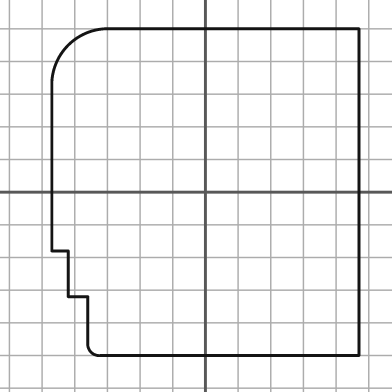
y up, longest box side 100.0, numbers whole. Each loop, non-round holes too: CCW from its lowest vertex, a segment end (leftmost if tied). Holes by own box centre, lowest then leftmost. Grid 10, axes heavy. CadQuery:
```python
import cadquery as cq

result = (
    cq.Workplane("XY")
    .moveTo(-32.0, -50.0)
    .lineTo(47.0, -50.0)
    .lineTo(47.0, 50.0)
    .lineTo(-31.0, 50.0)
    .threePointArc((-42.0, 45.0), (-47.0, 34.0))
    .lineTo(-47.0, -18.0)
    .lineTo(-42.0, -18.0)
    .lineTo(-42.0, -32.0)
    .lineTo(-36.0, -32.0)
    .lineTo(-36.0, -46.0)
    .threePointArc((-35.0, -49.0), (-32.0, -50.0))
    .close()
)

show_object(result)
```